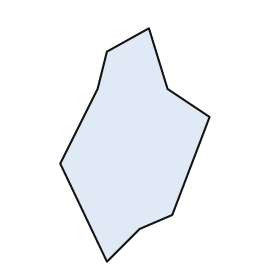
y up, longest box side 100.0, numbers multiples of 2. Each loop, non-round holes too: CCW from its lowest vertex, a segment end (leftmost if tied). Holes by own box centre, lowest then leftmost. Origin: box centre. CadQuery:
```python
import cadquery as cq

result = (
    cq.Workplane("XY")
    .moveTo(-12.0, -50.0)
    .lineTo(2.0, -36.0)
    .lineTo(16.0, -30.0)
    .lineTo(32.0, 12.0)
    .lineTo(14.0, 24.0)
    .lineTo(6.0, 50.0)
    .lineTo(-12.0, 40.0)
    .lineTo(-16.0, 24.0)
    .lineTo(-32.0, -8.0)
    .close()
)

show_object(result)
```